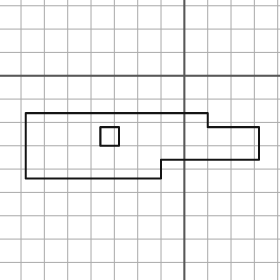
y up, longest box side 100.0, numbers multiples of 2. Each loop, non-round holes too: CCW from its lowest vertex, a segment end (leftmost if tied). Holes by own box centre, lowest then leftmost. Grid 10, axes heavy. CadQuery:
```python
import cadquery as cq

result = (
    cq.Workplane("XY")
    .moveTo(-68.0, -44.0)
    .lineTo(-10.0, -44.0)
    .lineTo(-10.0, -36.0)
    .lineTo(32.0, -36.0)
    .lineTo(32.0, -22.0)
    .lineTo(10.0, -22.0)
    .lineTo(10.0, -16.0)
    .lineTo(-68.0, -16.0)
    .close()
    .moveTo(-36.0, -30.0)
    .lineTo(-28.0, -30.0)
    .lineTo(-28.0, -22.0)
    .lineTo(-36.0, -22.0)
    .close()
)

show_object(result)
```